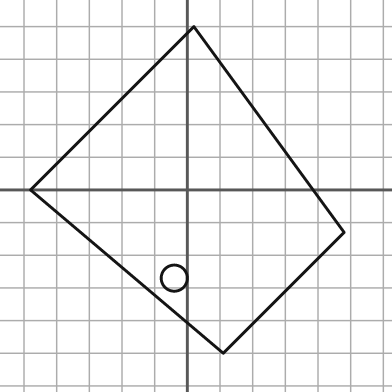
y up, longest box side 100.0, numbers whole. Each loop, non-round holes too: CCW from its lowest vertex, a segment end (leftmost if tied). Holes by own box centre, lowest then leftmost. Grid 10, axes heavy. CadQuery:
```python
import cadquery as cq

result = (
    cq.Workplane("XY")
    .moveTo(11.0, -50.0)
    .lineTo(48.0, -13.0)
    .lineTo(2.0, 50.0)
    .lineTo(-48.0, 0.0)
    .close()
    .moveTo(-4.0, -27.0)
    .circle(4.0)
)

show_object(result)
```